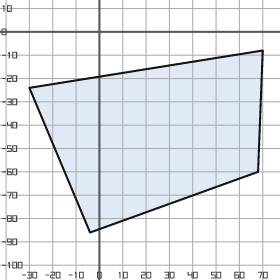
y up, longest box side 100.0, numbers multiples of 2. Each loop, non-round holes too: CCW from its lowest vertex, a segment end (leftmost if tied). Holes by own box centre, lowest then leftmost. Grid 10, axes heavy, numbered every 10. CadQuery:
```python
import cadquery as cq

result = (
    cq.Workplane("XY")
    .moveTo(-4.0, -86.0)
    .lineTo(68.0, -60.0)
    .lineTo(70.0, -8.0)
    .lineTo(-30.0, -24.0)
    .close()
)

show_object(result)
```